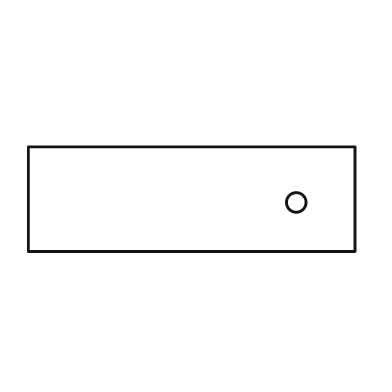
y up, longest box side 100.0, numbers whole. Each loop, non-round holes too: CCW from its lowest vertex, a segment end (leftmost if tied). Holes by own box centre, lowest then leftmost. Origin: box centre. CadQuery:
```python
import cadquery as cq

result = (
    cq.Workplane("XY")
    .moveTo(-50.0, -16.0)
    .lineTo(50.0, -16.0)
    .lineTo(50.0, 16.0)
    .lineTo(-50.0, 16.0)
    .close()
    .moveTo(32.0, -1.0)
    .circle(3.0)
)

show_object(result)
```